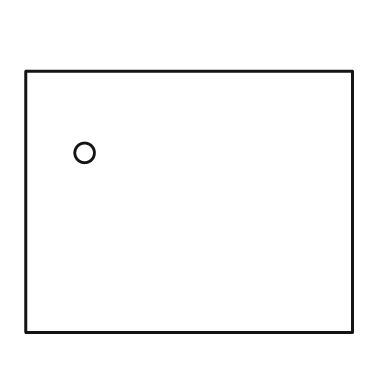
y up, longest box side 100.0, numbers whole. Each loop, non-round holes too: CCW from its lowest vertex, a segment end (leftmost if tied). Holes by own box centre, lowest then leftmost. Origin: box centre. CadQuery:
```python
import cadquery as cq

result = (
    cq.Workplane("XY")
    .moveTo(-50.0, -40.0)
    .lineTo(50.0, -40.0)
    .lineTo(50.0, 40.0)
    .lineTo(-50.0, 40.0)
    .close()
    .moveTo(-32.0, 15.0)
    .circle(3.0)
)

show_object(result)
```